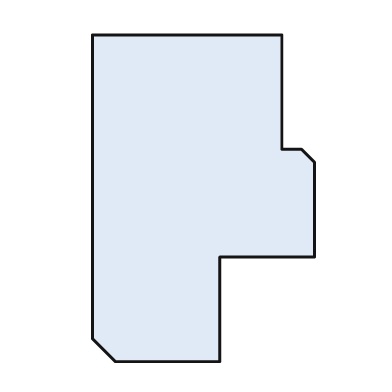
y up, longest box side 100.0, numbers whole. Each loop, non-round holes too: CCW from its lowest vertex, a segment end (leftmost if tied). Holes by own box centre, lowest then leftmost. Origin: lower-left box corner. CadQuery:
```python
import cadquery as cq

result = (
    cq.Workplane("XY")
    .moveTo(7.0, 0.0)
    .lineTo(39.0, 0.0)
    .lineTo(39.0, 32.0)
    .lineTo(68.0, 32.0)
    .lineTo(68.0, 61.0)
    .lineTo(64.0, 65.0)
    .lineTo(58.0, 65.0)
    .lineTo(58.0, 100.0)
    .lineTo(0.0, 100.0)
    .lineTo(0.0, 7.0)
    .close()
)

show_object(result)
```